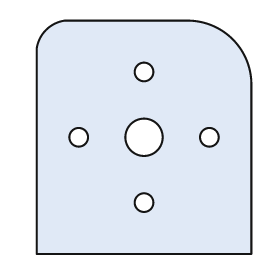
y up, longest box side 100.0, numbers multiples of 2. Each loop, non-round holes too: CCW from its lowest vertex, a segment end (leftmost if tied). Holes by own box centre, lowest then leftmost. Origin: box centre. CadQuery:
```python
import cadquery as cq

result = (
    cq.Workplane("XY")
    .moveTo(-46.0, -50.0)
    .lineTo(46.0, -50.0)
    .lineTo(46.0, 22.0)
    .threePointArc((38.0, 42.0), (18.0, 50.0))
    .lineTo(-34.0, 50.0)
    .threePointArc((-42.0, 46.0), (-46.0, 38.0))
    .close()
    .moveTo(0.0, -28.0)
    .circle(4.0)
    .moveTo(-28.0, 0.0)
    .circle(4.0)
    .moveTo(0.0, 0.0)
    .circle(8.0)
    .moveTo(28.0, 0.0)
    .circle(4.0)
    .moveTo(0.0, 28.0)
    .circle(4.0)
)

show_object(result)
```